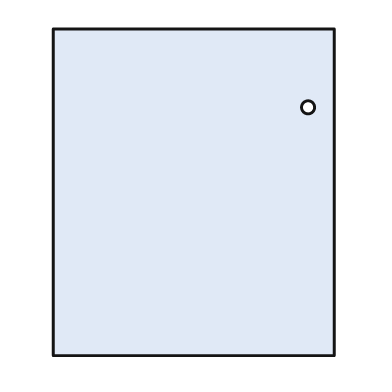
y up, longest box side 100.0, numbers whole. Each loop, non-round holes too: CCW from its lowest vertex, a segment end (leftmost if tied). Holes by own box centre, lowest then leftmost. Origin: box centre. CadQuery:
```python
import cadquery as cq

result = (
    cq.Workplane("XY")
    .moveTo(-43.0, -50.0)
    .lineTo(43.0, -50.0)
    .lineTo(43.0, 50.0)
    .lineTo(-43.0, 50.0)
    .close()
    .moveTo(35.0, 26.0)
    .circle(2.0)
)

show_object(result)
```